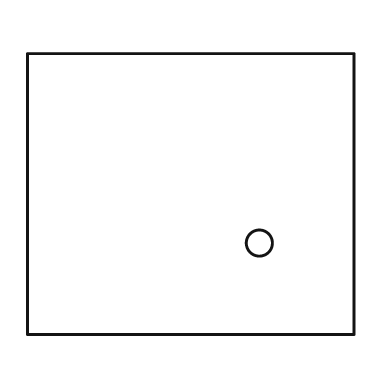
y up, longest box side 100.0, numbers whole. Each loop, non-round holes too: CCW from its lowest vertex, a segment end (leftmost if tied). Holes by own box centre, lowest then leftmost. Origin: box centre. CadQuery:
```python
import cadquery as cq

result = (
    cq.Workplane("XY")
    .moveTo(-50.0, -43.0)
    .lineTo(50.0, -43.0)
    .lineTo(50.0, 43.0)
    .lineTo(-50.0, 43.0)
    .close()
    .moveTo(21.0, -15.0)
    .circle(4.0)
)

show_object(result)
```